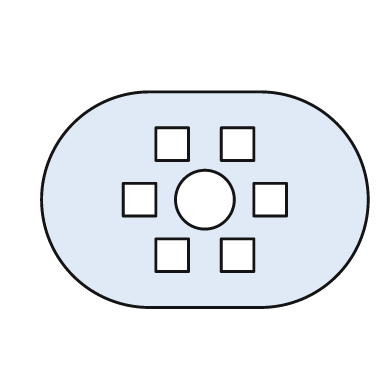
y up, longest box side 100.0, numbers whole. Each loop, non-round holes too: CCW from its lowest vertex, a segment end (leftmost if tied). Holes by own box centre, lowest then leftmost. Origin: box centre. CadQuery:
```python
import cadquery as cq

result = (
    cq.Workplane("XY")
    .moveTo(-17.0, -33.0)
    .lineTo(17.0, -33.0)
    .threePointArc((50.0, 0.0), (17.0, 33.0))
    .lineTo(-17.0, 33.0)
    .threePointArc((-50.0, 0.0), (-17.0, -33.0))
    .close()
    .moveTo(-15.0, -22.0)
    .lineTo(-5.0, -22.0)
    .lineTo(-5.0, -12.0)
    .lineTo(-15.0, -12.0)
    .close()
    .moveTo(5.0, -22.0)
    .lineTo(15.0, -22.0)
    .lineTo(15.0, -12.0)
    .lineTo(5.0, -12.0)
    .close()
    .moveTo(-25.0, -5.0)
    .lineTo(-15.0, -5.0)
    .lineTo(-15.0, 5.0)
    .lineTo(-25.0, 5.0)
    .close()
    .moveTo(0.0, 0.0)
    .circle(9.0)
    .moveTo(15.0, -5.0)
    .lineTo(25.0, -5.0)
    .lineTo(25.0, 5.0)
    .lineTo(15.0, 5.0)
    .close()
    .moveTo(-15.0, 12.0)
    .lineTo(-5.0, 12.0)
    .lineTo(-5.0, 22.0)
    .lineTo(-15.0, 22.0)
    .close()
    .moveTo(5.0, 12.0)
    .lineTo(15.0, 12.0)
    .lineTo(15.0, 22.0)
    .lineTo(5.0, 22.0)
    .close()
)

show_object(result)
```